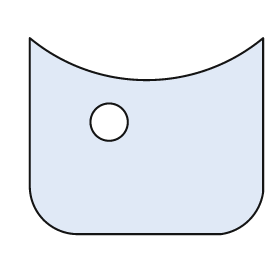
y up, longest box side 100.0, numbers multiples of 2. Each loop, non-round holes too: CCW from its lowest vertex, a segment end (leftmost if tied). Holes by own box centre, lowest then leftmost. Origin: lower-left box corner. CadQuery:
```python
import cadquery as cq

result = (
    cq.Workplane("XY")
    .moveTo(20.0, 0.0)
    .lineTo(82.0, 0.0)
    .threePointArc((94.0, 6.0), (100.0, 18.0))
    .lineTo(100.0, 84.0)
    .threePointArc((50.0, 66.0), (0.0, 84.0))
    .lineTo(0.0, 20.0)
    .threePointArc((6.0, 6.0), (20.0, 0.0))
    .close()
    .moveTo(34.0, 48.0)
    .circle(8.0)
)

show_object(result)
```